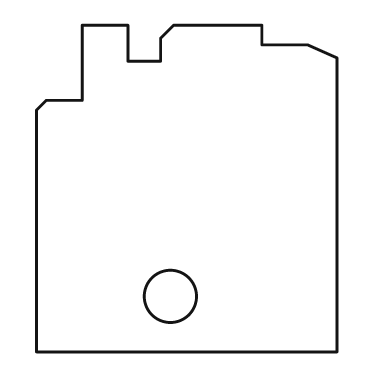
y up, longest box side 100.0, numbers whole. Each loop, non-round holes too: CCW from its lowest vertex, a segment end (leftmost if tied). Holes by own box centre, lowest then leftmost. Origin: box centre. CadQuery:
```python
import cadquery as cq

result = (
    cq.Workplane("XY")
    .moveTo(-46.0, -50.0)
    .lineTo(46.0, -50.0)
    .lineTo(46.0, 40.0)
    .lineTo(37.0, 44.0)
    .lineTo(23.0, 44.0)
    .lineTo(23.0, 50.0)
    .lineTo(-4.0, 50.0)
    .lineTo(-8.0, 46.0)
    .lineTo(-8.0, 39.0)
    .lineTo(-18.0, 39.0)
    .lineTo(-18.0, 50.0)
    .lineTo(-32.0, 50.0)
    .lineTo(-32.0, 27.0)
    .lineTo(-43.0, 27.0)
    .lineTo(-46.0, 24.0)
    .close()
    .moveTo(-5.0, -33.0)
    .circle(8.0)
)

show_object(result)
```